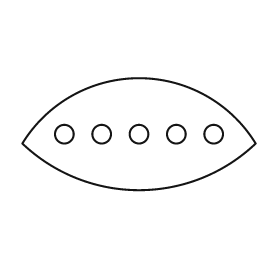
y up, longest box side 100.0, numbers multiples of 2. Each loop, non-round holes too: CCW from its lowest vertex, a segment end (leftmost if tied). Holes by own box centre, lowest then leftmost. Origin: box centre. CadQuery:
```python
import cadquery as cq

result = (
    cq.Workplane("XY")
    .moveTo(-50.0, -4.0)
    .threePointArc((0.0, -24.0), (50.0, -4.0))
    .threePointArc((0.0, 24.0), (-50.0, -4.0))
    .close()
    .moveTo(-32.0, 0.0)
    .circle(4.0)
    .moveTo(-16.0, 0.0)
    .circle(4.0)
    .moveTo(0.0, 0.0)
    .circle(4.0)
    .moveTo(16.0, 0.0)
    .circle(4.0)
    .moveTo(32.0, 0.0)
    .circle(4.0)
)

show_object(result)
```